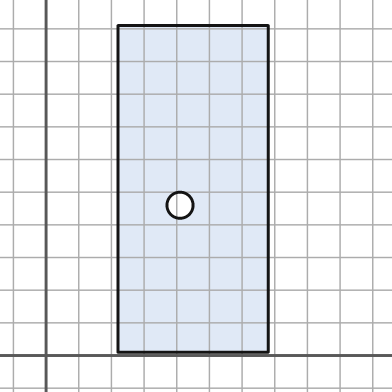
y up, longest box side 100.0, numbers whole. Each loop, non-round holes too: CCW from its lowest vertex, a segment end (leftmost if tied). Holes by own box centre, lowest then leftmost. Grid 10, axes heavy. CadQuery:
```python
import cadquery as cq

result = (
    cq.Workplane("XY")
    .moveTo(22.0, 1.0)
    .lineTo(68.0, 1.0)
    .lineTo(68.0, 101.0)
    .lineTo(22.0, 101.0)
    .close()
    .moveTo(41.0, 46.0)
    .circle(4.0)
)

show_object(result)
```